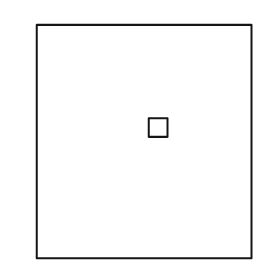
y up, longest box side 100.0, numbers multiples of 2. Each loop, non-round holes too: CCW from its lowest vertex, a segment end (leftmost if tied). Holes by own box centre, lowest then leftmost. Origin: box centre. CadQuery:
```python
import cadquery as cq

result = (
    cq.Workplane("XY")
    .moveTo(-46.0, -50.0)
    .lineTo(46.0, -50.0)
    .lineTo(46.0, 50.0)
    .lineTo(-46.0, 50.0)
    .close()
    .moveTo(2.0, 2.0)
    .lineTo(10.0, 2.0)
    .lineTo(10.0, 10.0)
    .lineTo(2.0, 10.0)
    .close()
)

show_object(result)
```